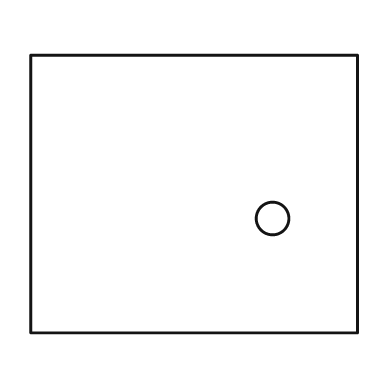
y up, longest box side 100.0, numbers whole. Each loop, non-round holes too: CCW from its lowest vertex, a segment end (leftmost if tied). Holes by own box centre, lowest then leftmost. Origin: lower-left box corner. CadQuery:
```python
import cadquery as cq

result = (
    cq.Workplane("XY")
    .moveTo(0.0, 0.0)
    .lineTo(100.0, 0.0)
    .lineTo(100.0, 85.0)
    .lineTo(0.0, 85.0)
    .close()
    .moveTo(74.0, 35.0)
    .circle(5.0)
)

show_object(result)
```